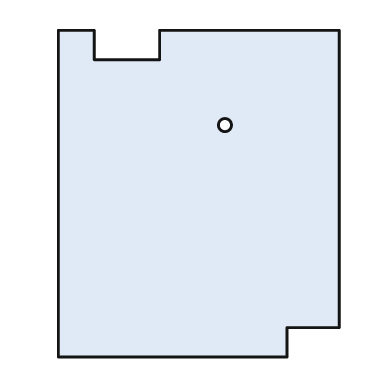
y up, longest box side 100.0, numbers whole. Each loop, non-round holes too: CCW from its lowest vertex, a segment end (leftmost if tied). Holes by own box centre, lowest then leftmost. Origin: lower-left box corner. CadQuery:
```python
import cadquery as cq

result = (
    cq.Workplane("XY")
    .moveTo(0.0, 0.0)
    .lineTo(70.0, 0.0)
    .lineTo(70.0, 9.0)
    .lineTo(86.0, 9.0)
    .lineTo(86.0, 100.0)
    .lineTo(31.0, 100.0)
    .lineTo(31.0, 91.0)
    .lineTo(11.0, 91.0)
    .lineTo(11.0, 100.0)
    .lineTo(0.0, 100.0)
    .close()
    .moveTo(51.0, 71.0)
    .circle(2.0)
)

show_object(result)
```